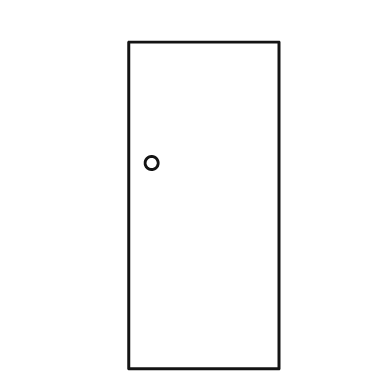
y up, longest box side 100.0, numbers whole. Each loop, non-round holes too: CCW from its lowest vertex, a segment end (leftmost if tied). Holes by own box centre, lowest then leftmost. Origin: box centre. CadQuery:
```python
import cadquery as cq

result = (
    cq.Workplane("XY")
    .moveTo(-23.0, -50.0)
    .lineTo(23.0, -50.0)
    .lineTo(23.0, 50.0)
    .lineTo(-23.0, 50.0)
    .close()
    .moveTo(-16.0, 13.0)
    .circle(2.0)
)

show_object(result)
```